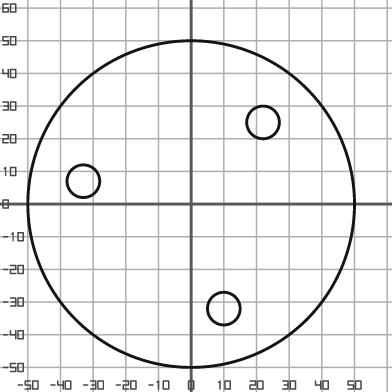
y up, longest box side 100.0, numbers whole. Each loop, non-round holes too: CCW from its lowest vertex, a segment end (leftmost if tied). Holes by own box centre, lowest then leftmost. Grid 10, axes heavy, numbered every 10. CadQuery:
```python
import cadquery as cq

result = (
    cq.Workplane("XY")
    .moveTo(0.0, 0.0)
    .circle(50.0)
    .moveTo(10.0, -32.0)
    .circle(5.0)
    .moveTo(-33.0, 7.0)
    .circle(5.0)
    .moveTo(22.0, 25.0)
    .circle(5.0)
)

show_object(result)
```